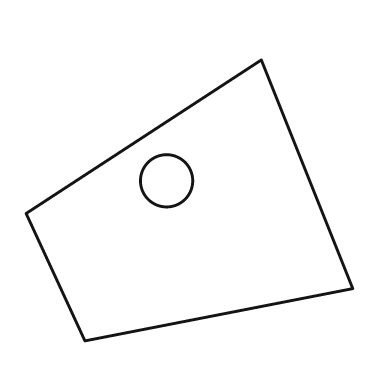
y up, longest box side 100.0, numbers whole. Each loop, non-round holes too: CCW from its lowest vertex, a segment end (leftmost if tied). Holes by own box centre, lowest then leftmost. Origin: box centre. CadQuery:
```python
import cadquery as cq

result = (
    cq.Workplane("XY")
    .moveTo(-32.0, -43.0)
    .lineTo(50.0, -27.0)
    .lineTo(22.0, 43.0)
    .lineTo(-50.0, -4.0)
    .close()
    .moveTo(-7.0, 6.0)
    .circle(8.0)
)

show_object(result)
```